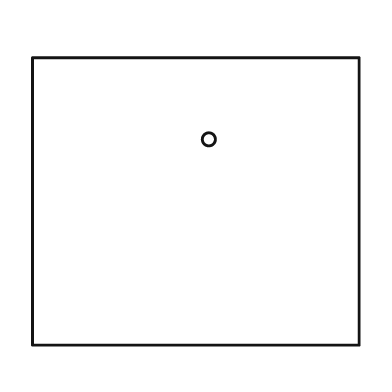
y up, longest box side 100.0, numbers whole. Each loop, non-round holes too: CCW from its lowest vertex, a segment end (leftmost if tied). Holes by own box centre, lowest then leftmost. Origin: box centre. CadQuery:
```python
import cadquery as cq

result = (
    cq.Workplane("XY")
    .moveTo(-50.0, -44.0)
    .lineTo(50.0, -44.0)
    .lineTo(50.0, 44.0)
    .lineTo(-50.0, 44.0)
    .close()
    .moveTo(4.0, 19.0)
    .circle(2.0)
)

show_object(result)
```